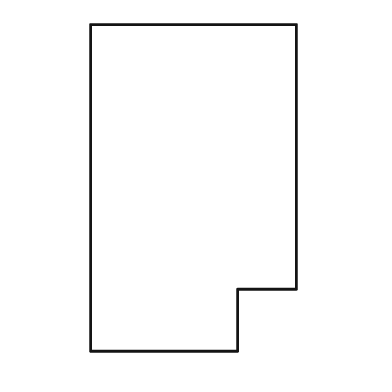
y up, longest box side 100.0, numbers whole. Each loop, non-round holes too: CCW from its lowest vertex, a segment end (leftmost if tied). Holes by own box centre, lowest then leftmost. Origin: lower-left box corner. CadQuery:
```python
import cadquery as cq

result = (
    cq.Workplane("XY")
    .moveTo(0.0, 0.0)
    .lineTo(45.0, 0.0)
    .lineTo(45.0, 19.0)
    .lineTo(63.0, 19.0)
    .lineTo(63.0, 100.0)
    .lineTo(0.0, 100.0)
    .close()
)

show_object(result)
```